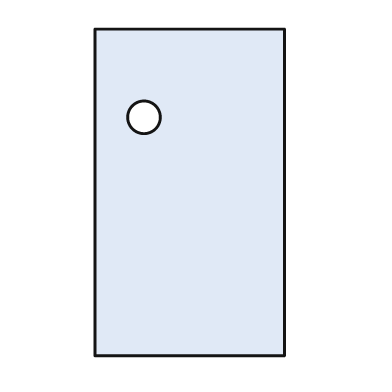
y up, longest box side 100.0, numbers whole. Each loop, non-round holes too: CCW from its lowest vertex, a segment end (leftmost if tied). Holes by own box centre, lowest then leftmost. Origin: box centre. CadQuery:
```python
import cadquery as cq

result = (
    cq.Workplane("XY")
    .moveTo(-29.0, -50.0)
    .lineTo(29.0, -50.0)
    .lineTo(29.0, 50.0)
    .lineTo(-29.0, 50.0)
    .close()
    .moveTo(-14.0, 23.0)
    .circle(5.0)
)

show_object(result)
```